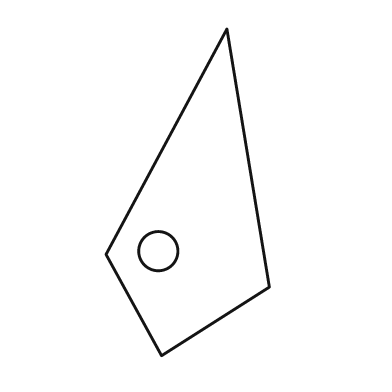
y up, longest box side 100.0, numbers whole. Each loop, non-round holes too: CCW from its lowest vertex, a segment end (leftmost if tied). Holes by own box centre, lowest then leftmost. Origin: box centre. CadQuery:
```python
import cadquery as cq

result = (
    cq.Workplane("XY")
    .moveTo(-8.0, -50.0)
    .lineTo(25.0, -29.0)
    .lineTo(12.0, 50.0)
    .lineTo(-25.0, -19.0)
    .close()
    .moveTo(-9.0, -18.0)
    .circle(6.0)
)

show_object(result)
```